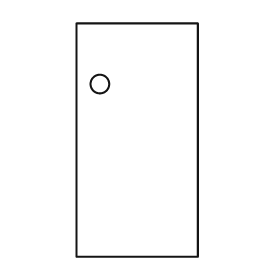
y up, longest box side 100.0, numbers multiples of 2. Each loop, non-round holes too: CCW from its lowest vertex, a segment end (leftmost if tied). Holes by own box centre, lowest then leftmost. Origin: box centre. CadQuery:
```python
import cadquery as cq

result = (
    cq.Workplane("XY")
    .moveTo(-26.0, -50.0)
    .lineTo(26.0, -50.0)
    .lineTo(26.0, 50.0)
    .lineTo(-26.0, 50.0)
    .close()
    .moveTo(-16.0, 24.0)
    .circle(4.0)
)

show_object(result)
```